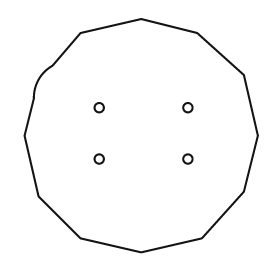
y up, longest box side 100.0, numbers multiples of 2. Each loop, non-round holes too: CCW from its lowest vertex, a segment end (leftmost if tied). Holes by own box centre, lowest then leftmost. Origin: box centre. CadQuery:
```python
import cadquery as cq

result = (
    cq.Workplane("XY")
    .moveTo(0.0, -50.0)
    .lineTo(26.0, -44.0)
    .lineTo(44.0, -24.0)
    .lineTo(50.0, 0.0)
    .lineTo(44.0, 26.0)
    .lineTo(24.0, 44.0)
    .lineTo(0.0, 50.0)
    .lineTo(-26.0, 44.0)
    .lineTo(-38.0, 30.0)
    .threePointArc((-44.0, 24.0), (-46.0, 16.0))
    .lineTo(-50.0, 0.0)
    .lineTo(-44.0, -26.0)
    .lineTo(-26.0, -44.0)
    .close()
    .moveTo(-18.0, -10.0)
    .circle(2.0)
    .moveTo(20.0, -10.0)
    .circle(2.0)
    .moveTo(-18.0, 12.0)
    .circle(2.0)
    .moveTo(20.0, 12.0)
    .circle(2.0)
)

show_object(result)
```